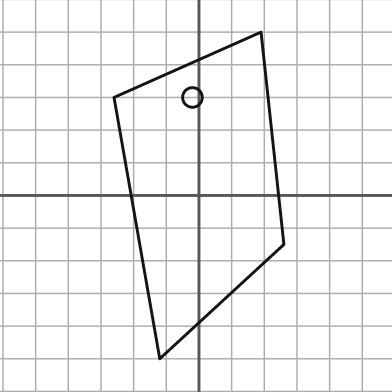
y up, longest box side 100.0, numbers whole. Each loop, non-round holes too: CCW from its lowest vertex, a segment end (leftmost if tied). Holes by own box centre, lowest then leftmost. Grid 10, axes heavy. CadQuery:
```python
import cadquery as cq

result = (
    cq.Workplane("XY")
    .moveTo(-12.0, -50.0)
    .lineTo(26.0, -15.0)
    .lineTo(19.0, 50.0)
    .lineTo(-26.0, 30.0)
    .close()
    .moveTo(-2.0, 30.0)
    .circle(3.0)
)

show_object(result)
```